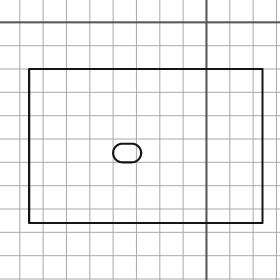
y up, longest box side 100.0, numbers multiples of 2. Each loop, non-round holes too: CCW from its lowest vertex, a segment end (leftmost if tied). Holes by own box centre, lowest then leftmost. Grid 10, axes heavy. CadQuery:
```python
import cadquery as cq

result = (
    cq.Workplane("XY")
    .moveTo(-76.0, -86.0)
    .lineTo(24.0, -86.0)
    .lineTo(24.0, -20.0)
    .lineTo(-76.0, -20.0)
    .close()
    .moveTo(-36.0, -60.0)
    .lineTo(-32.0, -60.0)
    .threePointArc((-28.0, -56.0), (-32.0, -52.0))
    .lineTo(-36.0, -52.0)
    .threePointArc((-40.0, -56.0), (-36.0, -60.0))
    .close()
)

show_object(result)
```